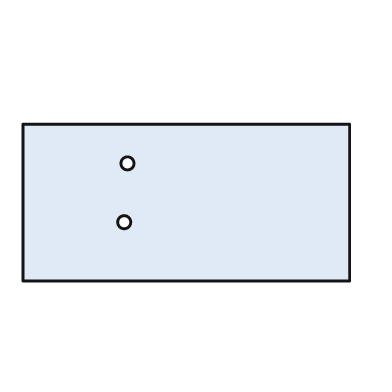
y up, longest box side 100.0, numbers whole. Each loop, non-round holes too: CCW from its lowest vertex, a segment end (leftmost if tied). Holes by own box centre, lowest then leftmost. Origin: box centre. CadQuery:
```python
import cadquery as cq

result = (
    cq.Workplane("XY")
    .moveTo(-50.0, -24.0)
    .lineTo(50.0, -24.0)
    .lineTo(50.0, 24.0)
    .lineTo(-50.0, 24.0)
    .close()
    .moveTo(-19.0, -6.0)
    .circle(2.0)
    .moveTo(-18.0, 12.0)
    .circle(2.0)
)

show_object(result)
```